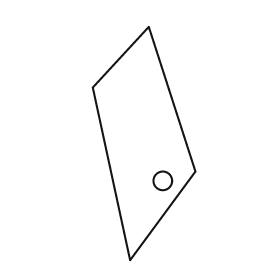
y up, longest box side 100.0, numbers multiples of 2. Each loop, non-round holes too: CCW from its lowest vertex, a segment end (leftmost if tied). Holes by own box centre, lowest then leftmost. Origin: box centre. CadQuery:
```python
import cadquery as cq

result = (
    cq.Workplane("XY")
    .moveTo(-6.0, -50.0)
    .lineTo(22.0, -12.0)
    .lineTo(2.0, 50.0)
    .lineTo(-22.0, 24.0)
    .close()
    .moveTo(8.0, -16.0)
    .circle(4.0)
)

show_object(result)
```